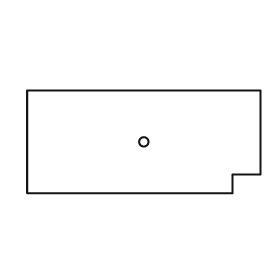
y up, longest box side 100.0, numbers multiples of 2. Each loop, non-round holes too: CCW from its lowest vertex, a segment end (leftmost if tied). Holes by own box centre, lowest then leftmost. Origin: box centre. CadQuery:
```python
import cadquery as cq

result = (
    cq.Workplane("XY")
    .moveTo(-50.0, -22.0)
    .lineTo(38.0, -22.0)
    .lineTo(38.0, -14.0)
    .lineTo(50.0, -14.0)
    .lineTo(50.0, 22.0)
    .lineTo(-50.0, 22.0)
    .close()
    .moveTo(0.0, 0.0)
    .circle(2.0)
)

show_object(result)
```